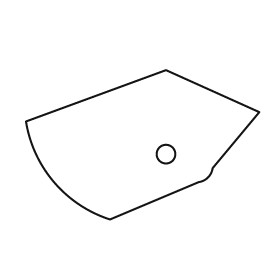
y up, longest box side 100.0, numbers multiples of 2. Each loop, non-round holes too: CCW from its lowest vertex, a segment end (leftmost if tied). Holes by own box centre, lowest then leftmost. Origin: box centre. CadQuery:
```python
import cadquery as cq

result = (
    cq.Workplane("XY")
    .moveTo(-14.0, -32.0)
    .lineTo(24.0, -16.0)
    .threePointArc((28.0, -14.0), (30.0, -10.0))
    .lineTo(50.0, 14.0)
    .lineTo(10.0, 32.0)
    .lineTo(-50.0, 10.0)
    .threePointArc((-38.0, -16.0), (-14.0, -32.0))
    .close()
    .moveTo(10.0, -4.0)
    .circle(4.0)
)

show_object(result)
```